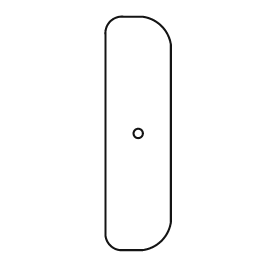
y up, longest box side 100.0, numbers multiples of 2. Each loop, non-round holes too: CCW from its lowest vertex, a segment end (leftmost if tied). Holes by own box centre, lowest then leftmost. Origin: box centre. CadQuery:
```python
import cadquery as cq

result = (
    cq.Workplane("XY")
    .moveTo(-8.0, -50.0)
    .lineTo(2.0, -50.0)
    .threePointArc((10.0, -46.0), (14.0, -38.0))
    .lineTo(14.0, 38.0)
    .threePointArc((10.0, 46.0), (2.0, 50.0))
    .lineTo(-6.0, 50.0)
    .threePointArc((-12.0, 48.0), (-14.0, 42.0))
    .lineTo(-14.0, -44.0)
    .threePointArc((-12.0, -48.0), (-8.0, -50.0))
    .close()
    .moveTo(0.0, 0.0)
    .circle(2.0)
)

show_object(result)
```